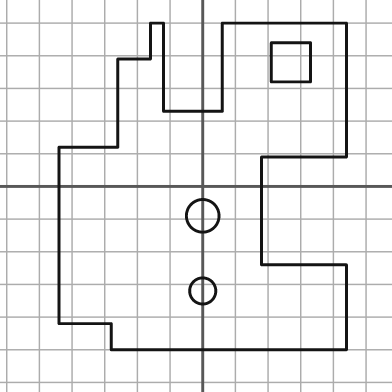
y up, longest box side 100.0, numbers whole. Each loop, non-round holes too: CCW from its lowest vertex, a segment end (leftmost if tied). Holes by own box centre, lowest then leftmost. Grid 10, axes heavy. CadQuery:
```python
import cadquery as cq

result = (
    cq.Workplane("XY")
    .moveTo(-28.0, -50.0)
    .lineTo(44.0, -50.0)
    .lineTo(44.0, -24.0)
    .lineTo(18.0, -24.0)
    .lineTo(18.0, 9.0)
    .lineTo(44.0, 9.0)
    .lineTo(44.0, 50.0)
    .lineTo(6.0, 50.0)
    .lineTo(6.0, 23.0)
    .lineTo(-12.0, 23.0)
    .lineTo(-12.0, 50.0)
    .lineTo(-16.0, 50.0)
    .lineTo(-16.0, 39.0)
    .lineTo(-26.0, 39.0)
    .lineTo(-26.0, 12.0)
    .lineTo(-44.0, 12.0)
    .lineTo(-44.0, -42.0)
    .lineTo(-28.0, -42.0)
    .close()
    .moveTo(0.0, -32.0)
    .circle(4.0)
    .moveTo(0.0, -9.0)
    .circle(5.0)
    .moveTo(21.0, 32.0)
    .lineTo(33.0, 32.0)
    .lineTo(33.0, 44.0)
    .lineTo(21.0, 44.0)
    .close()
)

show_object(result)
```